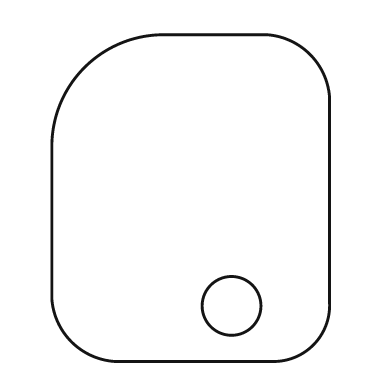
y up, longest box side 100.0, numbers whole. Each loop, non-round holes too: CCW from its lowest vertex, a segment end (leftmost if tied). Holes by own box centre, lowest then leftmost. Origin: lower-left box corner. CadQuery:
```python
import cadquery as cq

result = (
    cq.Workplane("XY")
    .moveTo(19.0, 0.0)
    .lineTo(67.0, 0.0)
    .threePointArc((80.0, 5.0), (85.0, 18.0))
    .lineTo(85.0, 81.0)
    .threePointArc((79.0, 94.0), (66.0, 100.0))
    .lineTo(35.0, 100.0)
    .threePointArc((10.0, 90.0), (0.0, 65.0))
    .lineTo(0.0, 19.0)
    .threePointArc((6.0, 6.0), (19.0, 0.0))
    .close()
    .moveTo(55.0, 17.0)
    .circle(9.0)
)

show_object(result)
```